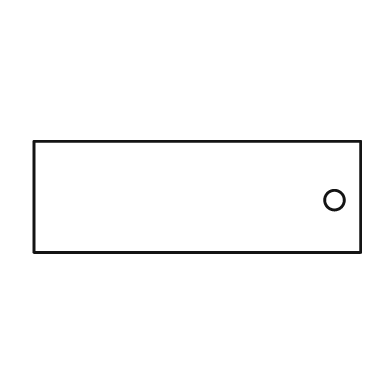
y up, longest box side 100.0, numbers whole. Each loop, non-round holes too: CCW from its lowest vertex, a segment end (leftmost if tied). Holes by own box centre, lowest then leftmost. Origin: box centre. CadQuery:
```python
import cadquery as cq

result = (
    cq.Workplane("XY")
    .moveTo(-50.0, -17.0)
    .lineTo(50.0, -17.0)
    .lineTo(50.0, 17.0)
    .lineTo(-50.0, 17.0)
    .close()
    .moveTo(42.0, -1.0)
    .circle(3.0)
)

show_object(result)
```